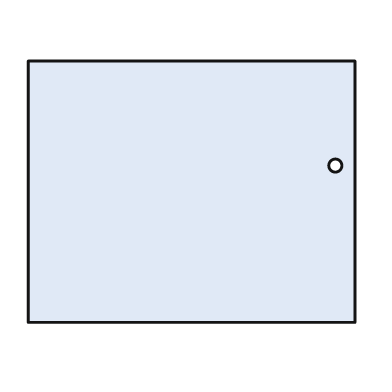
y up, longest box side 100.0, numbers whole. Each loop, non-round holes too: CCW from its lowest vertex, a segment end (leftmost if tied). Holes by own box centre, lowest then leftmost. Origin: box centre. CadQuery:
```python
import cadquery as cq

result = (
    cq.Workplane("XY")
    .moveTo(-50.0, -40.0)
    .lineTo(50.0, -40.0)
    .lineTo(50.0, 40.0)
    .lineTo(-50.0, 40.0)
    .close()
    .moveTo(44.0, 8.0)
    .circle(2.0)
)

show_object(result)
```